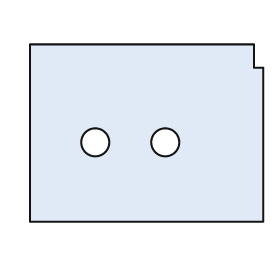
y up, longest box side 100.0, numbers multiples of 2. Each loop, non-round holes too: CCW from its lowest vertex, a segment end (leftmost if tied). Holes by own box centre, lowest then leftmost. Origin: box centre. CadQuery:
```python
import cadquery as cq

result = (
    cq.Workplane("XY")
    .moveTo(-50.0, -38.0)
    .lineTo(50.0, -38.0)
    .lineTo(50.0, 28.0)
    .lineTo(46.0, 28.0)
    .lineTo(46.0, 38.0)
    .lineTo(-50.0, 38.0)
    .close()
    .moveTo(-22.0, -4.0)
    .circle(6.0)
    .moveTo(8.0, -4.0)
    .circle(6.0)
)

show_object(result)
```